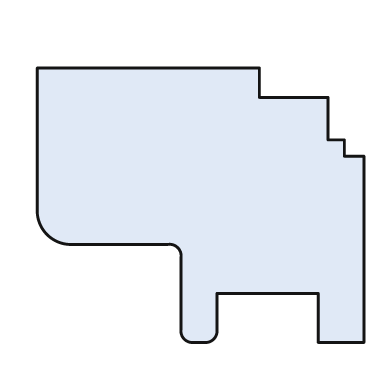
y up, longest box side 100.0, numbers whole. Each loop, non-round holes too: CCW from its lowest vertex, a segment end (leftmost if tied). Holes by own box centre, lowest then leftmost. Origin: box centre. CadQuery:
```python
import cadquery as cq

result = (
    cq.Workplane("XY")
    .moveTo(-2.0, -42.0)
    .lineTo(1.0, -42.0)
    .threePointArc((4.0, -41.0), (5.0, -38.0))
    .lineTo(5.0, -27.0)
    .lineTo(36.0, -27.0)
    .lineTo(36.0, -42.0)
    .lineTo(50.0, -42.0)
    .lineTo(50.0, 15.0)
    .lineTo(44.0, 15.0)
    .lineTo(44.0, 20.0)
    .lineTo(39.0, 20.0)
    .lineTo(39.0, 33.0)
    .lineTo(18.0, 33.0)
    .lineTo(18.0, 42.0)
    .lineTo(-50.0, 42.0)
    .lineTo(-50.0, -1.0)
    .threePointArc((-47.0, -9.0), (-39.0, -12.0))
    .lineTo(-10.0, -12.0)
    .threePointArc((-7.0, -13.0), (-6.0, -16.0))
    .lineTo(-6.0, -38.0)
    .threePointArc((-5.0, -41.0), (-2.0, -42.0))
    .close()
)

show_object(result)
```